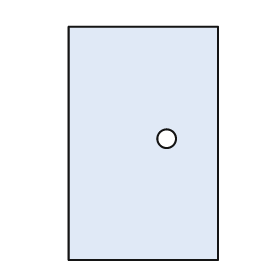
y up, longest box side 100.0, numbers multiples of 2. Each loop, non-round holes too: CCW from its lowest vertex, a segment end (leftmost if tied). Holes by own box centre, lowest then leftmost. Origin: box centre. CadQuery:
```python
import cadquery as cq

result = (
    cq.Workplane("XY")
    .moveTo(-32.0, -50.0)
    .lineTo(32.0, -50.0)
    .lineTo(32.0, 50.0)
    .lineTo(-32.0, 50.0)
    .close()
    .moveTo(10.0, 2.0)
    .circle(4.0)
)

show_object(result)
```